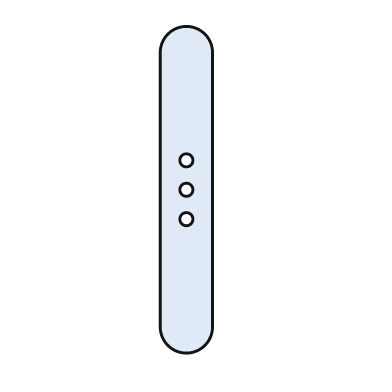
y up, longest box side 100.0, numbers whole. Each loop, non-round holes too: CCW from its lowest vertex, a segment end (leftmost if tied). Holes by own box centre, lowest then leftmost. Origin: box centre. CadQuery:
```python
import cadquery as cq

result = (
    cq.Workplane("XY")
    .moveTo(-8.0, -42.0)
    .threePointArc((0.0, -50.0), (8.0, -42.0))
    .lineTo(8.0, 42.0)
    .threePointArc((0.0, 50.0), (-8.0, 42.0))
    .close()
    .moveTo(0.0, -9.0)
    .circle(2.0)
    .moveTo(0.0, 0.0)
    .circle(2.0)
    .moveTo(0.0, 9.0)
    .circle(2.0)
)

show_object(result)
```